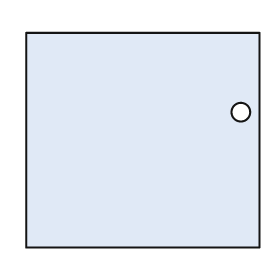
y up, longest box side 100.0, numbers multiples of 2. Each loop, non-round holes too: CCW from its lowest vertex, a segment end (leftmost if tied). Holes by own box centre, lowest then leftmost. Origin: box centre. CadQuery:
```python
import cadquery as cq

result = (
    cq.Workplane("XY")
    .moveTo(-50.0, -46.0)
    .lineTo(50.0, -46.0)
    .lineTo(50.0, 46.0)
    .lineTo(-50.0, 46.0)
    .close()
    .moveTo(42.0, 12.0)
    .circle(4.0)
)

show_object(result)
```